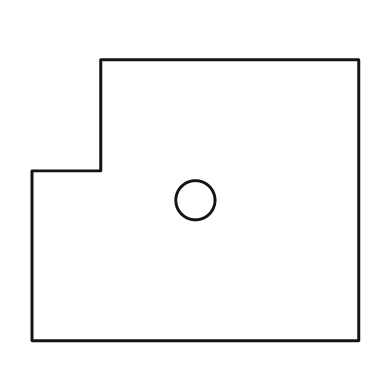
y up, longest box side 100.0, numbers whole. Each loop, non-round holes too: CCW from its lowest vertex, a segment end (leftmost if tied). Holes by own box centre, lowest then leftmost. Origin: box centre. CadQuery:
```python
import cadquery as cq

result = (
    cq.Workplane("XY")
    .moveTo(-50.0, -43.0)
    .lineTo(50.0, -43.0)
    .lineTo(50.0, 43.0)
    .lineTo(-29.0, 43.0)
    .lineTo(-29.0, 9.0)
    .lineTo(-50.0, 9.0)
    .close()
    .moveTo(0.0, 0.0)
    .circle(6.0)
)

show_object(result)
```